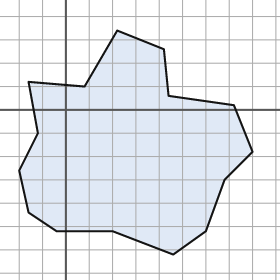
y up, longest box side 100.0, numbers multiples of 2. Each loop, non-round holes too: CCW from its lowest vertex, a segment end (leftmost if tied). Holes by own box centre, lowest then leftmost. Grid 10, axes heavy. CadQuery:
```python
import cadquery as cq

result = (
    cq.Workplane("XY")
    .moveTo(46.0, -62.0)
    .lineTo(60.0, -52.0)
    .lineTo(68.0, -30.0)
    .lineTo(80.0, -18.0)
    .lineTo(72.0, 2.0)
    .lineTo(44.0, 6.0)
    .lineTo(42.0, 26.0)
    .lineTo(22.0, 34.0)
    .lineTo(8.0, 10.0)
    .lineTo(-16.0, 12.0)
    .lineTo(-12.0, -10.0)
    .lineTo(-20.0, -26.0)
    .lineTo(-16.0, -44.0)
    .lineTo(-4.0, -52.0)
    .lineTo(20.0, -52.0)
    .close()
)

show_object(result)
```